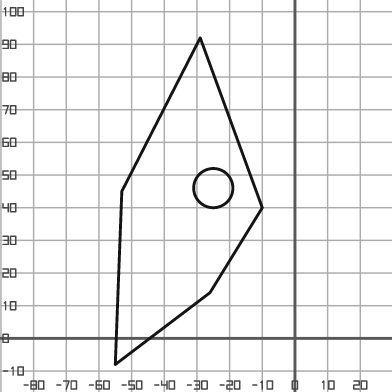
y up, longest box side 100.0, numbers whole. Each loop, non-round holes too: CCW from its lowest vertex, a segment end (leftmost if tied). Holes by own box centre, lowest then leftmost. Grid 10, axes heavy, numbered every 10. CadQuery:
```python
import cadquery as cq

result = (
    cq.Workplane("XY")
    .moveTo(-55.0, -8.0)
    .lineTo(-26.0, 14.0)
    .lineTo(-10.0, 40.0)
    .lineTo(-29.0, 92.0)
    .lineTo(-53.0, 45.0)
    .close()
    .moveTo(-25.0, 46.0)
    .circle(6.0)
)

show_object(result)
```